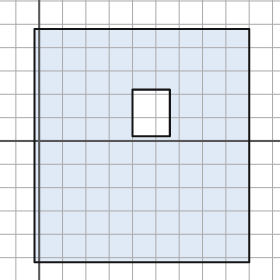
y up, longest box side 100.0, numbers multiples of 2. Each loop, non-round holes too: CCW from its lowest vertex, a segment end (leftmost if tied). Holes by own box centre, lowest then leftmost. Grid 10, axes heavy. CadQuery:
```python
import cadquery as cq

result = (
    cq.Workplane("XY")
    .moveTo(-2.0, -52.0)
    .lineTo(90.0, -52.0)
    .lineTo(90.0, 48.0)
    .lineTo(-2.0, 48.0)
    .close()
    .moveTo(40.0, 2.0)
    .lineTo(56.0, 2.0)
    .lineTo(56.0, 22.0)
    .lineTo(40.0, 22.0)
    .close()
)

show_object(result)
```